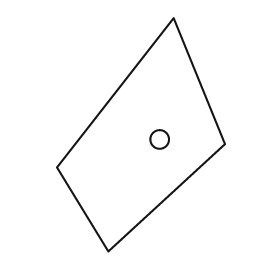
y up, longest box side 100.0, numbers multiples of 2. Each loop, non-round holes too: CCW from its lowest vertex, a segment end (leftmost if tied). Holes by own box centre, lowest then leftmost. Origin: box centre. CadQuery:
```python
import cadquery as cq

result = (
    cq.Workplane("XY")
    .moveTo(-14.0, -50.0)
    .lineTo(36.0, -4.0)
    .lineTo(14.0, 50.0)
    .lineTo(-36.0, -14.0)
    .close()
    .moveTo(8.0, -2.0)
    .circle(4.0)
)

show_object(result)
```